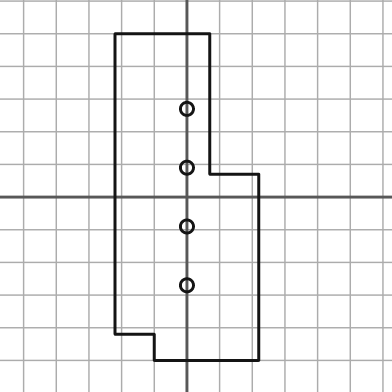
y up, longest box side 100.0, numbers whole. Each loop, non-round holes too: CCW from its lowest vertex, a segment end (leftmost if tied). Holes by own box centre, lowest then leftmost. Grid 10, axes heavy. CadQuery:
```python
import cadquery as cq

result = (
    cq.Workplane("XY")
    .moveTo(-10.0, -50.0)
    .lineTo(22.0, -50.0)
    .lineTo(22.0, 7.0)
    .lineTo(7.0, 7.0)
    .lineTo(7.0, 50.0)
    .lineTo(-22.0, 50.0)
    .lineTo(-22.0, -42.0)
    .lineTo(-10.0, -42.0)
    .close()
    .moveTo(0.0, -27.0)
    .circle(2.0)
    .moveTo(0.0, -9.0)
    .circle(2.0)
    .moveTo(0.0, 9.0)
    .circle(2.0)
    .moveTo(0.0, 27.0)
    .circle(2.0)
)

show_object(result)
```